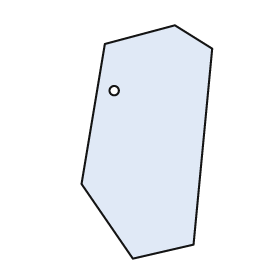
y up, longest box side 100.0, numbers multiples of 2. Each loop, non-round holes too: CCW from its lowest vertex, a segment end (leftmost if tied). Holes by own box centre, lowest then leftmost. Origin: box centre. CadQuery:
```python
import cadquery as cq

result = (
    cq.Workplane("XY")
    .moveTo(-6.0, -50.0)
    .lineTo(20.0, -44.0)
    .lineTo(28.0, 40.0)
    .lineTo(12.0, 50.0)
    .lineTo(-18.0, 42.0)
    .lineTo(-28.0, -18.0)
    .close()
    .moveTo(-14.0, 22.0)
    .circle(2.0)
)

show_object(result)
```